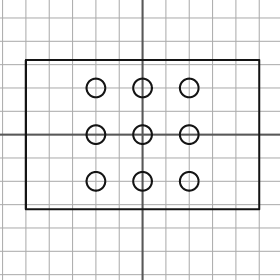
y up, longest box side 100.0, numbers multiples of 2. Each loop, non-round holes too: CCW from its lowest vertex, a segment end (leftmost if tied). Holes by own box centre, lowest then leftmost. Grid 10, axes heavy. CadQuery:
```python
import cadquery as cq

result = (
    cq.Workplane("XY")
    .moveTo(-50.0, -32.0)
    .lineTo(50.0, -32.0)
    .lineTo(50.0, 32.0)
    .lineTo(-50.0, 32.0)
    .close()
    .moveTo(-20.0, -20.0)
    .circle(4.0)
    .moveTo(0.0, -20.0)
    .circle(4.0)
    .moveTo(20.0, -20.0)
    .circle(4.0)
    .moveTo(-20.0, 0.0)
    .circle(4.0)
    .moveTo(0.0, 0.0)
    .circle(4.0)
    .moveTo(20.0, 0.0)
    .circle(4.0)
    .moveTo(-20.0, 20.0)
    .circle(4.0)
    .moveTo(0.0, 20.0)
    .circle(4.0)
    .moveTo(20.0, 20.0)
    .circle(4.0)
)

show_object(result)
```